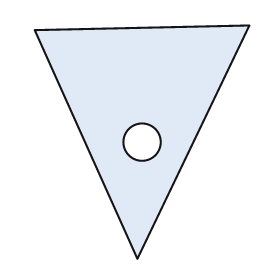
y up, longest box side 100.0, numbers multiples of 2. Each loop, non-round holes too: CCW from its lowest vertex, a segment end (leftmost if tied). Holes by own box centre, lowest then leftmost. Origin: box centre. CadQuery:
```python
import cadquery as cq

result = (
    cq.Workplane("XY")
    .moveTo(-2.0, -50.0)
    .lineTo(46.0, 50.0)
    .lineTo(-46.0, 48.0)
    .close()
    .moveTo(0.0, 0.0)
    .circle(8.0)
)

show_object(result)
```